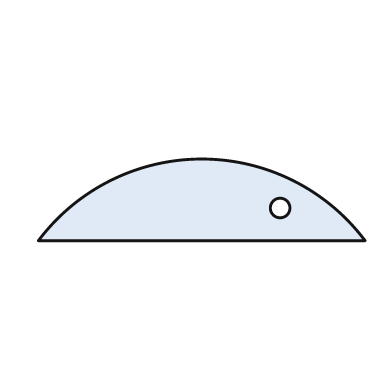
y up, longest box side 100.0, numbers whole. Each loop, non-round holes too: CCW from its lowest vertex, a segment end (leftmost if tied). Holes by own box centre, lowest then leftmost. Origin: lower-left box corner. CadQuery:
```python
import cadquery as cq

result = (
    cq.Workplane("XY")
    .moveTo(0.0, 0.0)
    .lineTo(100.0, 0.0)
    .threePointArc((50.0, 25.0), (0.0, 0.0))
    .close()
    .moveTo(74.0, 10.0)
    .circle(3.0)
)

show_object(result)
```